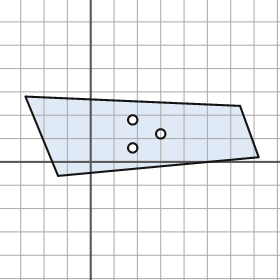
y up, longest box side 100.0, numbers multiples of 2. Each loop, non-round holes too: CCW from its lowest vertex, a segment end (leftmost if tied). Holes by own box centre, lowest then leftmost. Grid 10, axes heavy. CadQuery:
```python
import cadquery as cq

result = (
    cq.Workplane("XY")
    .moveTo(-14.0, -6.0)
    .lineTo(72.0, 2.0)
    .lineTo(64.0, 24.0)
    .lineTo(-28.0, 28.0)
    .close()
    .moveTo(18.0, 6.0)
    .circle(2.0)
    .moveTo(30.0, 12.0)
    .circle(2.0)
    .moveTo(18.0, 18.0)
    .circle(2.0)
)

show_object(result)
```